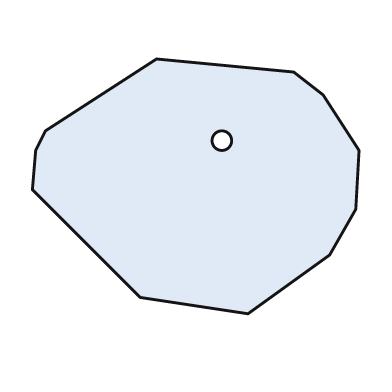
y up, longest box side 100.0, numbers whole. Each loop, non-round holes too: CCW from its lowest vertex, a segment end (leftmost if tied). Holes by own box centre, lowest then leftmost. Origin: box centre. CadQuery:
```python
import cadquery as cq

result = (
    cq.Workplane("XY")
    .moveTo(16.0, -39.0)
    .lineTo(41.0, -21.0)
    .lineTo(49.0, -7.0)
    .lineTo(50.0, 11.0)
    .lineTo(39.0, 28.0)
    .lineTo(30.0, 35.0)
    .lineTo(-12.0, 39.0)
    .lineTo(-46.0, 17.0)
    .lineTo(-49.0, 11.0)
    .lineTo(-50.0, -1.0)
    .lineTo(-17.0, -34.0)
    .close()
    .moveTo(8.0, 14.0)
    .circle(3.0)
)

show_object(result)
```